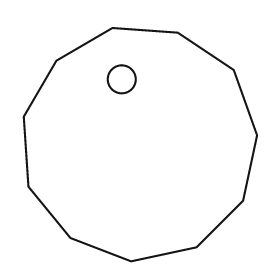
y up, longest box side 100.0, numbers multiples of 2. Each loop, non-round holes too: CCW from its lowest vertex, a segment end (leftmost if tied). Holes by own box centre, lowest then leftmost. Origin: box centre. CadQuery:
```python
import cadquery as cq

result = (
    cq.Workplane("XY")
    .moveTo(-4.0, -50.0)
    .lineTo(24.0, -44.0)
    .lineTo(44.0, -24.0)
    .lineTo(50.0, 4.0)
    .lineTo(40.0, 32.0)
    .lineTo(16.0, 48.0)
    .lineTo(-12.0, 50.0)
    .lineTo(-36.0, 36.0)
    .lineTo(-50.0, 12.0)
    .lineTo(-48.0, -18.0)
    .lineTo(-30.0, -40.0)
    .close()
    .moveTo(-8.0, 28.0)
    .circle(6.0)
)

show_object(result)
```